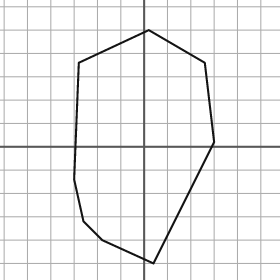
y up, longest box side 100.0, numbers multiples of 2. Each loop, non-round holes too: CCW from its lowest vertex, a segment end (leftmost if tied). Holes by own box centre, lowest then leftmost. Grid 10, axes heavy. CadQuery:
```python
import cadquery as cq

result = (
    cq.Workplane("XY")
    .moveTo(4.0, -50.0)
    .lineTo(30.0, 2.0)
    .lineTo(26.0, 36.0)
    .lineTo(2.0, 50.0)
    .lineTo(-28.0, 36.0)
    .lineTo(-30.0, -14.0)
    .lineTo(-26.0, -32.0)
    .lineTo(-18.0, -40.0)
    .close()
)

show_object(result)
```